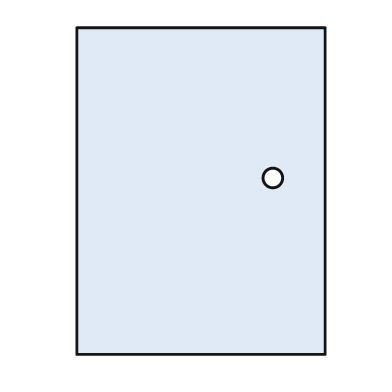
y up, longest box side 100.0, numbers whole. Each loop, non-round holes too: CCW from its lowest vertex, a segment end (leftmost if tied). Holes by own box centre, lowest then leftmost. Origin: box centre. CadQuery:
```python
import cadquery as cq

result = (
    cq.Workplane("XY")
    .moveTo(-38.0, -50.0)
    .lineTo(38.0, -50.0)
    .lineTo(38.0, 50.0)
    .lineTo(-38.0, 50.0)
    .close()
    .moveTo(22.0, 4.0)
    .circle(3.0)
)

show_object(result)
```